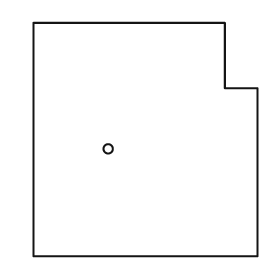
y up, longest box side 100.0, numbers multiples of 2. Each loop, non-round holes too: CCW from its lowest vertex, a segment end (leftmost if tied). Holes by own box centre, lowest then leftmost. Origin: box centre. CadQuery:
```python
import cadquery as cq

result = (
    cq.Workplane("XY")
    .moveTo(-48.0, -50.0)
    .lineTo(48.0, -50.0)
    .lineTo(48.0, 22.0)
    .lineTo(34.0, 22.0)
    .lineTo(34.0, 50.0)
    .lineTo(-48.0, 50.0)
    .close()
    .moveTo(-16.0, -4.0)
    .circle(2.0)
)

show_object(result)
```